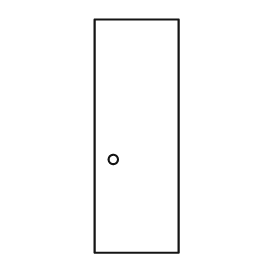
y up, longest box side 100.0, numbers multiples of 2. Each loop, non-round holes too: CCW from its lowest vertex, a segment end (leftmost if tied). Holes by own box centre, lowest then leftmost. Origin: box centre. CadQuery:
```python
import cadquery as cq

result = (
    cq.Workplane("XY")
    .moveTo(-18.0, -50.0)
    .lineTo(18.0, -50.0)
    .lineTo(18.0, 50.0)
    .lineTo(-18.0, 50.0)
    .close()
    .moveTo(-10.0, -10.0)
    .circle(2.0)
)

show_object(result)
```